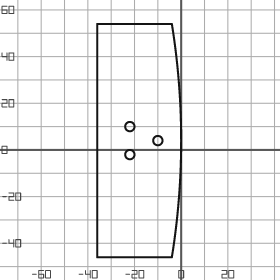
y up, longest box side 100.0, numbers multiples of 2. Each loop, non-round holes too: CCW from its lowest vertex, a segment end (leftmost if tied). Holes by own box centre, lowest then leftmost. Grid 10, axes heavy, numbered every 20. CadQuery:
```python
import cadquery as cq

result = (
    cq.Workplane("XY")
    .moveTo(-36.0, -46.0)
    .lineTo(-4.0, -46.0)
    .threePointArc((0.0, 4.0), (-4.0, 54.0))
    .lineTo(-36.0, 54.0)
    .close()
    .moveTo(-22.0, -2.0)
    .circle(2.0)
    .moveTo(-10.0, 4.0)
    .circle(2.0)
    .moveTo(-22.0, 10.0)
    .circle(2.0)
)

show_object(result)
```